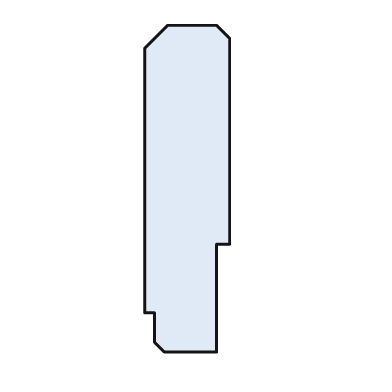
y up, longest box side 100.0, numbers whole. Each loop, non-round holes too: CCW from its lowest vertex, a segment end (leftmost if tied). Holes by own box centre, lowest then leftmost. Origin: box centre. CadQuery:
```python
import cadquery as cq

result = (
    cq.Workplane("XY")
    .moveTo(-7.0, -50.0)
    .lineTo(9.0, -50.0)
    .lineTo(9.0, -17.0)
    .lineTo(13.0, -17.0)
    .lineTo(13.0, 46.0)
    .lineTo(9.0, 50.0)
    .lineTo(-6.0, 50.0)
    .lineTo(-13.0, 43.0)
    .lineTo(-13.0, -38.0)
    .lineTo(-10.0, -38.0)
    .lineTo(-10.0, -47.0)
    .close()
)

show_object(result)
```